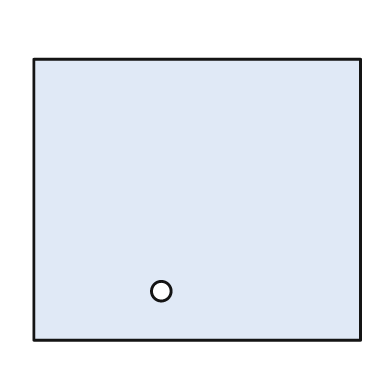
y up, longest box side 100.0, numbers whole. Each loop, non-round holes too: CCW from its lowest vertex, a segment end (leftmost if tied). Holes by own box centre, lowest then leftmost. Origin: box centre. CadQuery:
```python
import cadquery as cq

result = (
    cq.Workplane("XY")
    .moveTo(-50.0, -43.0)
    .lineTo(50.0, -43.0)
    .lineTo(50.0, 43.0)
    .lineTo(-50.0, 43.0)
    .close()
    .moveTo(-11.0, -28.0)
    .circle(3.0)
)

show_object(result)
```